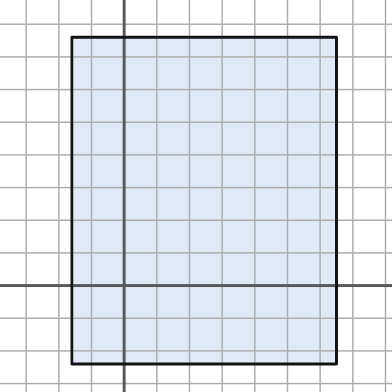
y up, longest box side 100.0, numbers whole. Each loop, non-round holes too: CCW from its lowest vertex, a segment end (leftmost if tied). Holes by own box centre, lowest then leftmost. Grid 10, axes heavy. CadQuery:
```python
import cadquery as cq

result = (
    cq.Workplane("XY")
    .moveTo(-16.0, -24.0)
    .lineTo(65.0, -24.0)
    .lineTo(65.0, 76.0)
    .lineTo(-16.0, 76.0)
    .close()
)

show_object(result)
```